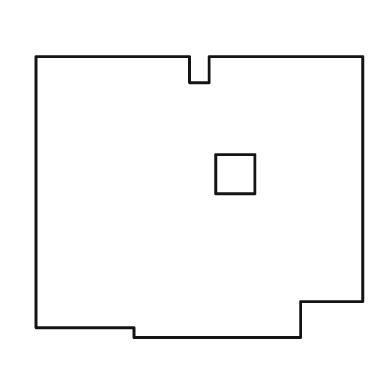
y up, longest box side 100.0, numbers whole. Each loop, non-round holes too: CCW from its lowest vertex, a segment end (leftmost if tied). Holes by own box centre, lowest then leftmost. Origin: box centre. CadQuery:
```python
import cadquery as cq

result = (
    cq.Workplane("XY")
    .moveTo(-20.0, -43.0)
    .lineTo(31.0, -43.0)
    .lineTo(31.0, -32.0)
    .lineTo(50.0, -32.0)
    .lineTo(50.0, 43.0)
    .lineTo(3.0, 43.0)
    .lineTo(3.0, 35.0)
    .lineTo(-3.0, 35.0)
    .lineTo(-3.0, 43.0)
    .lineTo(-50.0, 43.0)
    .lineTo(-50.0, -40.0)
    .lineTo(-20.0, -40.0)
    .close()
    .moveTo(5.0, 1.0)
    .lineTo(17.0, 1.0)
    .lineTo(17.0, 13.0)
    .lineTo(5.0, 13.0)
    .close()
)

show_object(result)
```